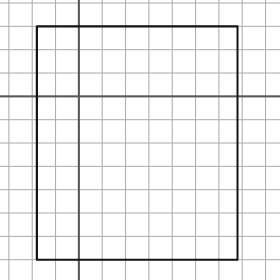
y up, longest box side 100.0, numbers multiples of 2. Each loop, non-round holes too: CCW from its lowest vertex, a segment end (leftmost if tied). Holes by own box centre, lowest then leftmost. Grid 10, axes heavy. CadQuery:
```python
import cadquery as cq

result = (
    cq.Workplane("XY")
    .moveTo(-18.0, -70.0)
    .lineTo(68.0, -70.0)
    .lineTo(68.0, 30.0)
    .lineTo(-18.0, 30.0)
    .close()
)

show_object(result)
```